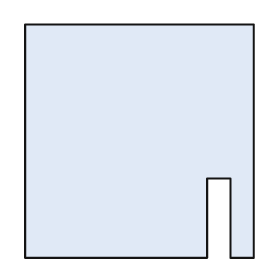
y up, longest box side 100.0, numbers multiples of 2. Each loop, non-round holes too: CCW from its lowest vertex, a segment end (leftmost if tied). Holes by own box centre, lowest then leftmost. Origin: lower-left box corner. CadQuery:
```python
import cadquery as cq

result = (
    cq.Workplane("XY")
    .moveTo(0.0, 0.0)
    .lineTo(78.0, 0.0)
    .lineTo(78.0, 34.0)
    .lineTo(88.0, 34.0)
    .lineTo(88.0, 0.0)
    .lineTo(98.0, 0.0)
    .lineTo(98.0, 100.0)
    .lineTo(0.0, 100.0)
    .close()
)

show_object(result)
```